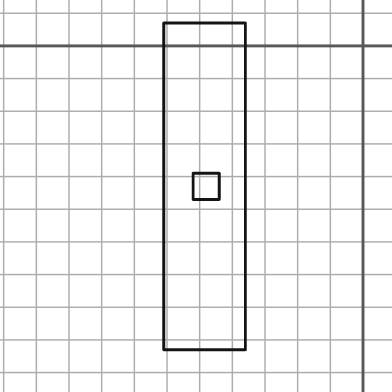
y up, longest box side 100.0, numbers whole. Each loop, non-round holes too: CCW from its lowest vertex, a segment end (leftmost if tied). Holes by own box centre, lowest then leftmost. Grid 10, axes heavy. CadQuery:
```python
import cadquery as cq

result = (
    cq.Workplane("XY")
    .moveTo(-61.0, -93.0)
    .lineTo(-36.0, -93.0)
    .lineTo(-36.0, 7.0)
    .lineTo(-61.0, 7.0)
    .close()
    .moveTo(-52.0, -47.0)
    .lineTo(-44.0, -47.0)
    .lineTo(-44.0, -39.0)
    .lineTo(-52.0, -39.0)
    .close()
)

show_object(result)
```